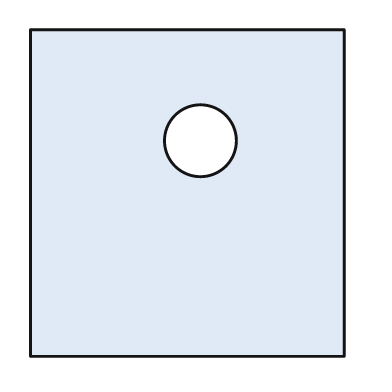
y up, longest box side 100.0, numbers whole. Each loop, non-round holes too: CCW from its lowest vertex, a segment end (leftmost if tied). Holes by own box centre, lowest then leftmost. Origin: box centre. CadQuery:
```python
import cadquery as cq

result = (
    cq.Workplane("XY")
    .moveTo(-48.0, -50.0)
    .lineTo(48.0, -50.0)
    .lineTo(48.0, 50.0)
    .lineTo(-48.0, 50.0)
    .close()
    .moveTo(4.0, 16.0)
    .circle(11.0)
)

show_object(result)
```